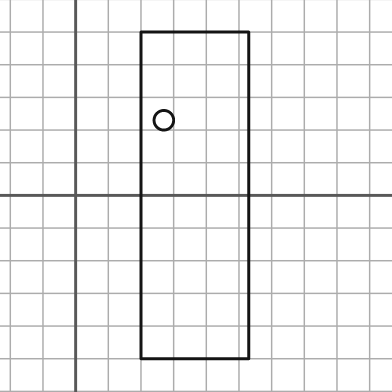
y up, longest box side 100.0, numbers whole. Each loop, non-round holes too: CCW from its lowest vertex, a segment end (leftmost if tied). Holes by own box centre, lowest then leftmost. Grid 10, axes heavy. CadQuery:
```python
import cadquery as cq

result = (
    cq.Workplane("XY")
    .moveTo(20.0, -50.0)
    .lineTo(53.0, -50.0)
    .lineTo(53.0, 50.0)
    .lineTo(20.0, 50.0)
    .close()
    .moveTo(27.0, 23.0)
    .circle(3.0)
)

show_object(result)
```